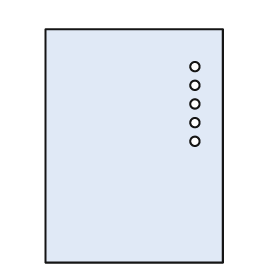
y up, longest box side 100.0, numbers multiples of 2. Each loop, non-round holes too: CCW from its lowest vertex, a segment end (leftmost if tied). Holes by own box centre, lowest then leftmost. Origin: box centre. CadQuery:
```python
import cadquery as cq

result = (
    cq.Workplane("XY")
    .moveTo(-38.0, -50.0)
    .lineTo(38.0, -50.0)
    .lineTo(38.0, 50.0)
    .lineTo(-38.0, 50.0)
    .close()
    .moveTo(26.0, 2.0)
    .circle(2.0)
    .moveTo(26.0, 10.0)
    .circle(2.0)
    .moveTo(26.0, 18.0)
    .circle(2.0)
    .moveTo(26.0, 26.0)
    .circle(2.0)
    .moveTo(26.0, 34.0)
    .circle(2.0)
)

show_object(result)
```